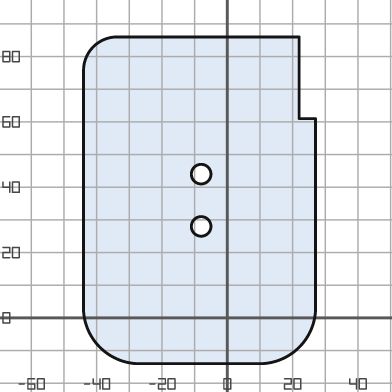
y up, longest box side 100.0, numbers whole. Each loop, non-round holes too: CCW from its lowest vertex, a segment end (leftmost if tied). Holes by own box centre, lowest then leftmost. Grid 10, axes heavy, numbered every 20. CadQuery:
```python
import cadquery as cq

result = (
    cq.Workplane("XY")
    .moveTo(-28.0, -14.0)
    .lineTo(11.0, -14.0)
    .threePointArc((22.0, -9.0), (27.0, 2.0))
    .lineTo(27.0, 61.0)
    .lineTo(22.0, 61.0)
    .lineTo(22.0, 86.0)
    .lineTo(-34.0, 86.0)
    .threePointArc((-41.0, 83.0), (-44.0, 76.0))
    .lineTo(-44.0, 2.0)
    .threePointArc((-39.0, -9.0), (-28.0, -14.0))
    .close()
    .moveTo(-8.0, 28.0)
    .circle(3.0)
    .moveTo(-8.0, 44.0)
    .circle(3.0)
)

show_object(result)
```